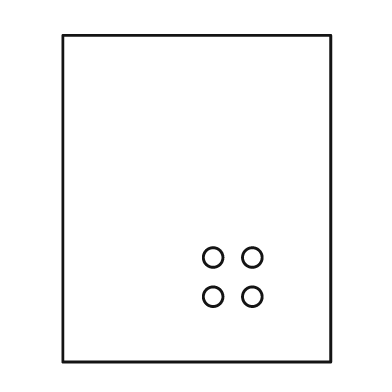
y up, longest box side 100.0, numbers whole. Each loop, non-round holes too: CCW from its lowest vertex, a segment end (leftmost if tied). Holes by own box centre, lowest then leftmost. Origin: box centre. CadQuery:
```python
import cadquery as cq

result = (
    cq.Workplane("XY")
    .moveTo(-41.0, -50.0)
    .lineTo(41.0, -50.0)
    .lineTo(41.0, 50.0)
    .lineTo(-41.0, 50.0)
    .close()
    .moveTo(5.0, -30.0)
    .circle(3.0)
    .moveTo(17.0, -30.0)
    .circle(3.0)
    .moveTo(5.0, -18.0)
    .circle(3.0)
    .moveTo(17.0, -18.0)
    .circle(3.0)
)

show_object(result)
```